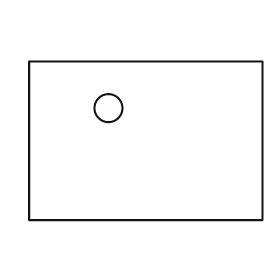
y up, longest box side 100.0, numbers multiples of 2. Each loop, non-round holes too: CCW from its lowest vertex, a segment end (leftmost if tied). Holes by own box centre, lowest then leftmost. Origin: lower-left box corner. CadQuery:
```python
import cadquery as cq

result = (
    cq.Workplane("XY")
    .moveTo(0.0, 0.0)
    .lineTo(100.0, 0.0)
    .lineTo(100.0, 68.0)
    .lineTo(0.0, 68.0)
    .close()
    .moveTo(34.0, 48.0)
    .circle(6.0)
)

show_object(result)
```